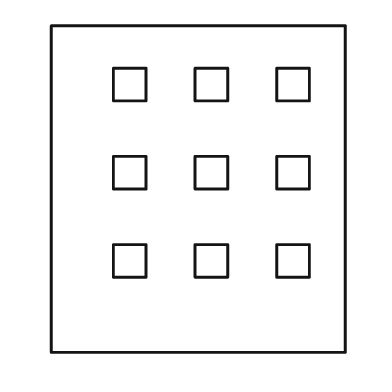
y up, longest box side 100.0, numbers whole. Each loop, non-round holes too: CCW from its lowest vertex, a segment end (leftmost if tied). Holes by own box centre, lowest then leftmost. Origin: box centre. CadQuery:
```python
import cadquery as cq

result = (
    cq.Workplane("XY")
    .moveTo(-45.0, -50.0)
    .lineTo(45.0, -50.0)
    .lineTo(45.0, 50.0)
    .lineTo(-45.0, 50.0)
    .close()
    .moveTo(-26.0, -27.0)
    .lineTo(-16.0, -27.0)
    .lineTo(-16.0, -17.0)
    .lineTo(-26.0, -17.0)
    .close()
    .moveTo(-1.0, -27.0)
    .lineTo(9.0, -27.0)
    .lineTo(9.0, -17.0)
    .lineTo(-1.0, -17.0)
    .close()
    .moveTo(24.0, -27.0)
    .lineTo(34.0, -27.0)
    .lineTo(34.0, -17.0)
    .lineTo(24.0, -17.0)
    .close()
    .moveTo(-26.0, 0.0)
    .lineTo(-16.0, 0.0)
    .lineTo(-16.0, 10.0)
    .lineTo(-26.0, 10.0)
    .close()
    .moveTo(-1.0, 0.0)
    .lineTo(9.0, 0.0)
    .lineTo(9.0, 10.0)
    .lineTo(-1.0, 10.0)
    .close()
    .moveTo(24.0, 0.0)
    .lineTo(34.0, 0.0)
    .lineTo(34.0, 10.0)
    .lineTo(24.0, 10.0)
    .close()
    .moveTo(-26.0, 27.0)
    .lineTo(-16.0, 27.0)
    .lineTo(-16.0, 37.0)
    .lineTo(-26.0, 37.0)
    .close()
    .moveTo(-1.0, 27.0)
    .lineTo(9.0, 27.0)
    .lineTo(9.0, 37.0)
    .lineTo(-1.0, 37.0)
    .close()
    .moveTo(24.0, 27.0)
    .lineTo(34.0, 27.0)
    .lineTo(34.0, 37.0)
    .lineTo(24.0, 37.0)
    .close()
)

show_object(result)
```